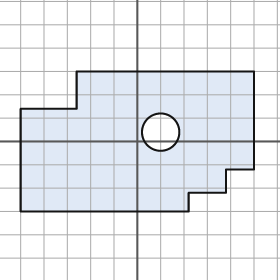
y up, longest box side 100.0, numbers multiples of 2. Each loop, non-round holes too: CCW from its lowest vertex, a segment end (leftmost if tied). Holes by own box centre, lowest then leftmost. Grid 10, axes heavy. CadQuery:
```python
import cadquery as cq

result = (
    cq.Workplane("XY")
    .moveTo(-50.0, -30.0)
    .lineTo(22.0, -30.0)
    .lineTo(22.0, -22.0)
    .lineTo(38.0, -22.0)
    .lineTo(38.0, -12.0)
    .lineTo(50.0, -12.0)
    .lineTo(50.0, 30.0)
    .lineTo(-26.0, 30.0)
    .lineTo(-26.0, 14.0)
    .lineTo(-50.0, 14.0)
    .close()
    .moveTo(10.0, 4.0)
    .circle(8.0)
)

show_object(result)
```